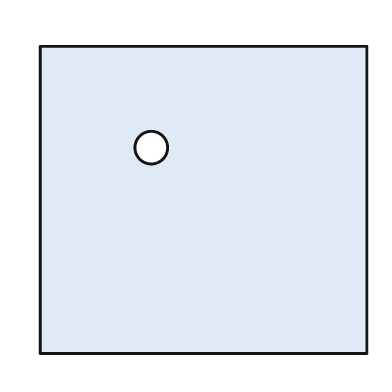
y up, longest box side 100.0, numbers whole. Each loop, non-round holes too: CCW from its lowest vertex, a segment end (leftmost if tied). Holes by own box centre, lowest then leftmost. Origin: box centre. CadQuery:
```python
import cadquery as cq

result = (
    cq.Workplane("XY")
    .moveTo(-50.0, -47.0)
    .lineTo(50.0, -47.0)
    .lineTo(50.0, 47.0)
    .lineTo(-50.0, 47.0)
    .close()
    .moveTo(-16.0, 16.0)
    .circle(5.0)
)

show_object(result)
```